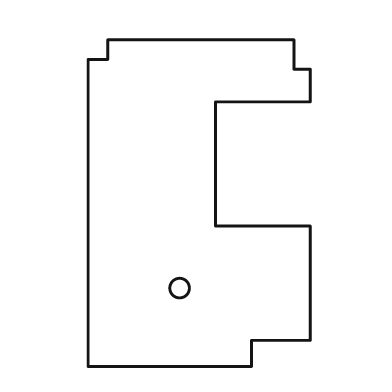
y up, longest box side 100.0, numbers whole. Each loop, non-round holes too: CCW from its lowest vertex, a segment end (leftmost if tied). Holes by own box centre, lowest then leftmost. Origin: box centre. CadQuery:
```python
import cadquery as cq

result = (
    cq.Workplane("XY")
    .moveTo(-34.0, -50.0)
    .lineTo(16.0, -50.0)
    .lineTo(16.0, -42.0)
    .lineTo(34.0, -42.0)
    .lineTo(34.0, -7.0)
    .lineTo(5.0, -7.0)
    .lineTo(5.0, 31.0)
    .lineTo(34.0, 31.0)
    .lineTo(34.0, 41.0)
    .lineTo(29.0, 41.0)
    .lineTo(29.0, 50.0)
    .lineTo(-28.0, 50.0)
    .lineTo(-28.0, 44.0)
    .lineTo(-34.0, 44.0)
    .close()
    .moveTo(-6.0, -26.0)
    .circle(3.0)
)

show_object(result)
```